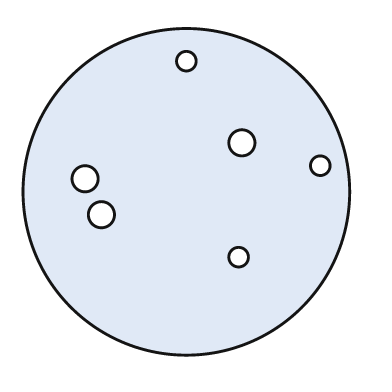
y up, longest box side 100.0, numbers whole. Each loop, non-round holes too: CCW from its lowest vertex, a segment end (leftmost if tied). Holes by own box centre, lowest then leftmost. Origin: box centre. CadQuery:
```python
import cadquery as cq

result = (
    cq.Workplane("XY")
    .moveTo(0.0, 0.0)
    .circle(50.0)
    .moveTo(16.0, -20.0)
    .circle(3.0)
    .moveTo(-26.0, -7.0)
    .circle(4.0)
    .moveTo(-31.0, 4.0)
    .circle(4.0)
    .moveTo(41.0, 8.0)
    .circle(3.0)
    .moveTo(17.0, 15.0)
    .circle(4.0)
    .moveTo(0.0, 40.0)
    .circle(3.0)
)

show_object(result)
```